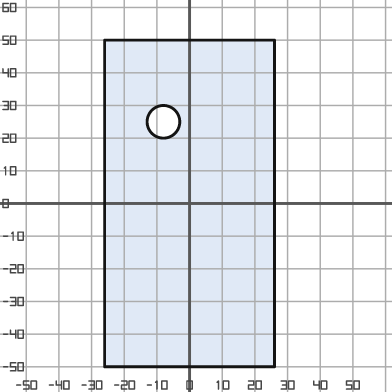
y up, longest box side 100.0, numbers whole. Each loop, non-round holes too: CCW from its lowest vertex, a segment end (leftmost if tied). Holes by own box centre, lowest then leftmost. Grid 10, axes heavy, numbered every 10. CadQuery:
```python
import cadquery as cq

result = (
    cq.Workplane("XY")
    .moveTo(-26.0, -50.0)
    .lineTo(26.0, -50.0)
    .lineTo(26.0, 50.0)
    .lineTo(-26.0, 50.0)
    .close()
    .moveTo(-8.0, 25.0)
    .circle(5.0)
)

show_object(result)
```